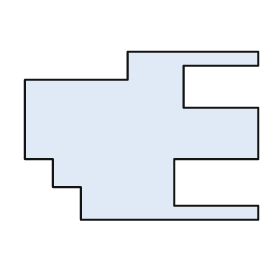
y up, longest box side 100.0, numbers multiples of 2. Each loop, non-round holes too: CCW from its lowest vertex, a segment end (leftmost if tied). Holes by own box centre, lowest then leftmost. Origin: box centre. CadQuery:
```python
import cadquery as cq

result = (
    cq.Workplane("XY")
    .moveTo(-26.0, -36.0)
    .lineTo(50.0, -36.0)
    .lineTo(50.0, -30.0)
    .lineTo(14.0, -30.0)
    .lineTo(14.0, -10.0)
    .lineTo(50.0, -10.0)
    .lineTo(50.0, 12.0)
    .lineTo(18.0, 12.0)
    .lineTo(18.0, 30.0)
    .lineTo(50.0, 30.0)
    .lineTo(50.0, 36.0)
    .lineTo(-6.0, 36.0)
    .lineTo(-6.0, 24.0)
    .lineTo(-50.0, 24.0)
    .lineTo(-50.0, -10.0)
    .lineTo(-38.0, -10.0)
    .lineTo(-38.0, -22.0)
    .lineTo(-26.0, -22.0)
    .close()
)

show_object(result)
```